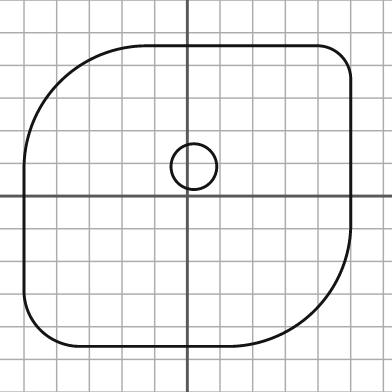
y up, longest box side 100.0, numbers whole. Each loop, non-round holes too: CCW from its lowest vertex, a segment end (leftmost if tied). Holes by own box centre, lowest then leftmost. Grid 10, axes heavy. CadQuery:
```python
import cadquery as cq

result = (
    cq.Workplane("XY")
    .moveTo(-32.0, -46.0)
    .lineTo(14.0, -46.0)
    .threePointArc((39.0, -35.0), (50.0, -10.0))
    .lineTo(50.0, 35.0)
    .threePointArc((47.0, 43.0), (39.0, 46.0))
    .lineTo(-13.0, 46.0)
    .threePointArc((-39.0, 35.0), (-50.0, 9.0))
    .lineTo(-50.0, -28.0)
    .threePointArc((-45.0, -41.0), (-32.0, -46.0))
    .close()
    .moveTo(2.0, 9.0)
    .circle(7.0)
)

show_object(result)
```